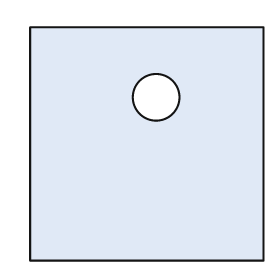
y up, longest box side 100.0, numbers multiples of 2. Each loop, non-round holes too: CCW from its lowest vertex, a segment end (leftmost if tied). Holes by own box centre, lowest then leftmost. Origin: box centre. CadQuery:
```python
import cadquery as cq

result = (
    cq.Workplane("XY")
    .moveTo(-50.0, -50.0)
    .lineTo(50.0, -50.0)
    .lineTo(50.0, 50.0)
    .lineTo(-50.0, 50.0)
    .close()
    .moveTo(4.0, 20.0)
    .circle(10.0)
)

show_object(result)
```